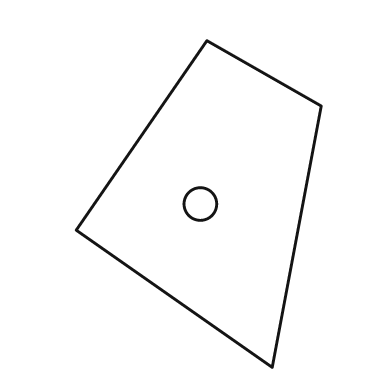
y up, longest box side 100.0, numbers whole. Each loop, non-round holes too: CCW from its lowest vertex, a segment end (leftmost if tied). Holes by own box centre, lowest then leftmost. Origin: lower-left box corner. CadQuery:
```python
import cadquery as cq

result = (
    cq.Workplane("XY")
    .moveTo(60.0, 0.0)
    .lineTo(75.0, 80.0)
    .lineTo(40.0, 100.0)
    .lineTo(0.0, 42.0)
    .close()
    .moveTo(38.0, 50.0)
    .circle(5.0)
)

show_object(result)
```